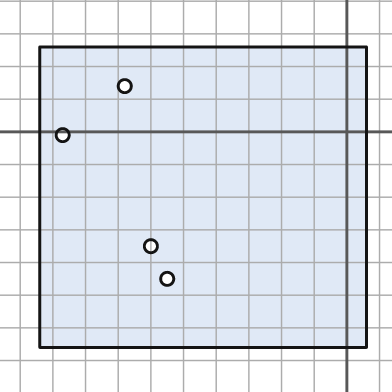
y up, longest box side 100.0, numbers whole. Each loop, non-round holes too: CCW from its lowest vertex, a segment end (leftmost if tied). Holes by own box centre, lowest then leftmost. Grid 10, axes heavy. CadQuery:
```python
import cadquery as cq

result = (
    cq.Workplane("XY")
    .moveTo(-94.0, -66.0)
    .lineTo(6.0, -66.0)
    .lineTo(6.0, 26.0)
    .lineTo(-94.0, 26.0)
    .close()
    .moveTo(-55.0, -45.0)
    .circle(2.0)
    .moveTo(-60.0, -35.0)
    .circle(2.0)
    .moveTo(-87.0, -1.0)
    .circle(2.0)
    .moveTo(-68.0, 14.0)
    .circle(2.0)
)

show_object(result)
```